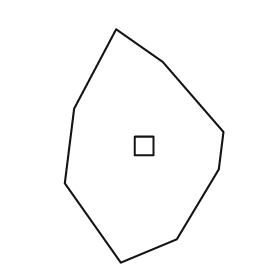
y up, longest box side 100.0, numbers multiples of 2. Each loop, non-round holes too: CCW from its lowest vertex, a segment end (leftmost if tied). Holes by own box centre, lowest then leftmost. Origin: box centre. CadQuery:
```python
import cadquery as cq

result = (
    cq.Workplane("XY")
    .moveTo(-10.0, -50.0)
    .lineTo(14.0, -40.0)
    .lineTo(32.0, -10.0)
    .lineTo(34.0, 6.0)
    .lineTo(8.0, 36.0)
    .lineTo(-12.0, 50.0)
    .lineTo(-30.0, 16.0)
    .lineTo(-34.0, -16.0)
    .close()
    .moveTo(-4.0, -4.0)
    .lineTo(4.0, -4.0)
    .lineTo(4.0, 4.0)
    .lineTo(-4.0, 4.0)
    .close()
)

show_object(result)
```